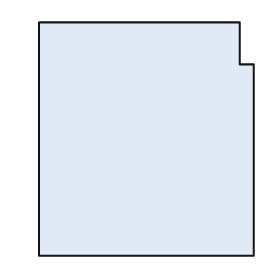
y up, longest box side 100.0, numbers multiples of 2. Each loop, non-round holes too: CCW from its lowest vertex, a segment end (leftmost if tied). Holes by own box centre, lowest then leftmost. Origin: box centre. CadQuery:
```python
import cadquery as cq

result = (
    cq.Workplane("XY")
    .moveTo(-46.0, -50.0)
    .lineTo(46.0, -50.0)
    .lineTo(46.0, 32.0)
    .lineTo(40.0, 32.0)
    .lineTo(40.0, 50.0)
    .lineTo(-46.0, 50.0)
    .close()
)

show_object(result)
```